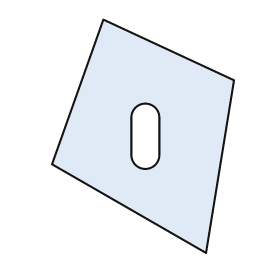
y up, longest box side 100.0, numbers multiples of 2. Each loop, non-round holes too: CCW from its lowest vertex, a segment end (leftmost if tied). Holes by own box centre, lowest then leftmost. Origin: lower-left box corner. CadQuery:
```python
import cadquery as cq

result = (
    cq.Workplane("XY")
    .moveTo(66.0, 0.0)
    .lineTo(78.0, 74.0)
    .lineTo(22.0, 100.0)
    .lineTo(0.0, 38.0)
    .close()
    .moveTo(34.0, 42.0)
    .threePointArc((40.0, 36.0), (46.0, 42.0))
    .lineTo(46.0, 58.0)
    .threePointArc((40.0, 64.0), (34.0, 58.0))
    .close()
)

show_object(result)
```